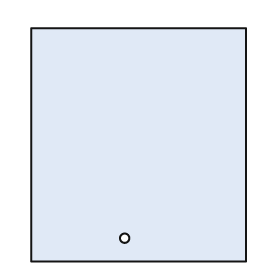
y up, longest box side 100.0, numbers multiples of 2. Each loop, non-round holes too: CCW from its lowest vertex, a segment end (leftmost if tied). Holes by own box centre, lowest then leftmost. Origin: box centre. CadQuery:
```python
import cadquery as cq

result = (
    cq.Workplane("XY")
    .moveTo(-46.0, -50.0)
    .lineTo(46.0, -50.0)
    .lineTo(46.0, 50.0)
    .lineTo(-46.0, 50.0)
    .close()
    .moveTo(-6.0, -40.0)
    .circle(2.0)
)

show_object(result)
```